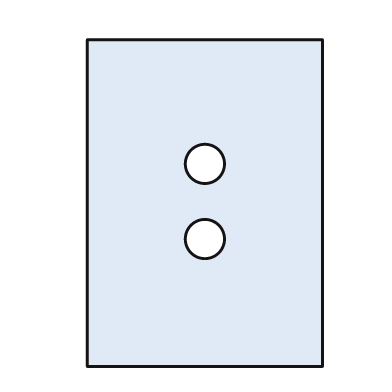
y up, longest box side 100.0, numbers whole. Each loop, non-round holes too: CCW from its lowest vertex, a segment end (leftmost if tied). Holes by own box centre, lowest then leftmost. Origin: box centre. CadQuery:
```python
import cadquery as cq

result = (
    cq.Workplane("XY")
    .moveTo(-36.0, -50.0)
    .lineTo(36.0, -50.0)
    .lineTo(36.0, 50.0)
    .lineTo(-36.0, 50.0)
    .close()
    .moveTo(0.0, -11.0)
    .circle(6.0)
    .moveTo(0.0, 12.0)
    .circle(6.0)
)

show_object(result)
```